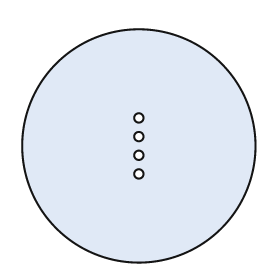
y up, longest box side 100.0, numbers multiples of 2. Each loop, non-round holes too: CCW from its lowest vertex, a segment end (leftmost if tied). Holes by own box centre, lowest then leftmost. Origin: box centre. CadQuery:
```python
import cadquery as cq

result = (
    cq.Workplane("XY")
    .moveTo(0.0, 0.0)
    .circle(50.0)
    .moveTo(0.0, -12.0)
    .circle(2.0)
    .moveTo(0.0, -4.0)
    .circle(2.0)
    .moveTo(0.0, 4.0)
    .circle(2.0)
    .moveTo(0.0, 12.0)
    .circle(2.0)
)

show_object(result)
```